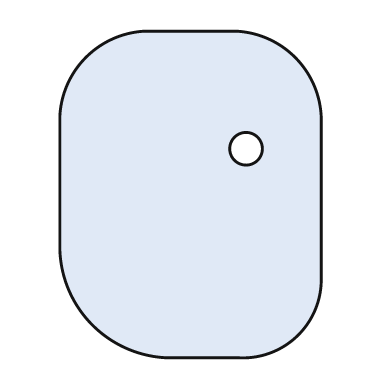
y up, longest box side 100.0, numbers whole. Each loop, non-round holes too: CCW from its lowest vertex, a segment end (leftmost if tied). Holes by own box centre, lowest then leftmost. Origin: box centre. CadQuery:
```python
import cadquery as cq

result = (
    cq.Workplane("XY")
    .moveTo(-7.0, -50.0)
    .lineTo(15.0, -50.0)
    .threePointArc((33.0, -43.0), (40.0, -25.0))
    .lineTo(40.0, 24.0)
    .threePointArc((32.0, 42.0), (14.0, 50.0))
    .lineTo(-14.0, 50.0)
    .threePointArc((-32.0, 42.0), (-40.0, 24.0))
    .lineTo(-40.0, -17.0)
    .threePointArc((-30.0, -40.0), (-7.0, -50.0))
    .close()
    .moveTo(17.0, 14.0)
    .circle(5.0)
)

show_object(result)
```